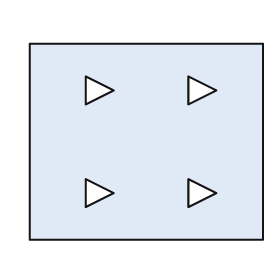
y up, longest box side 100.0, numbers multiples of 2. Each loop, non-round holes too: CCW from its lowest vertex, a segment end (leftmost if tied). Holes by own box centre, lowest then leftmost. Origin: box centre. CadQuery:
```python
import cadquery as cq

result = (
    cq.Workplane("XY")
    .moveTo(-50.0, -42.0)
    .lineTo(50.0, -42.0)
    .lineTo(50.0, 42.0)
    .lineTo(-50.0, 42.0)
    .close()
    .moveTo(-26.0, -28.0)
    .lineTo(-14.0, -22.0)
    .lineTo(-26.0, -16.0)
    .close()
    .moveTo(18.0, -28.0)
    .lineTo(30.0, -22.0)
    .lineTo(18.0, -16.0)
    .close()
    .moveTo(-26.0, 16.0)
    .lineTo(-14.0, 22.0)
    .lineTo(-26.0, 28.0)
    .close()
    .moveTo(18.0, 16.0)
    .lineTo(30.0, 22.0)
    .lineTo(18.0, 28.0)
    .close()
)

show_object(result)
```